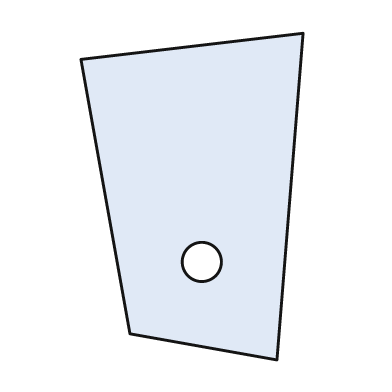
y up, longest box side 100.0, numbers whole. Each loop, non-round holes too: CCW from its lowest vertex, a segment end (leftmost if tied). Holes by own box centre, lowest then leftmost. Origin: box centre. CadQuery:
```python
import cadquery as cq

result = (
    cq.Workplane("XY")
    .moveTo(26.0, -50.0)
    .lineTo(34.0, 50.0)
    .lineTo(-34.0, 42.0)
    .lineTo(-19.0, -42.0)
    .close()
    .moveTo(3.0, -20.0)
    .circle(6.0)
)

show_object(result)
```